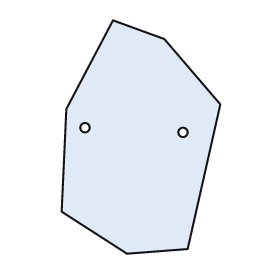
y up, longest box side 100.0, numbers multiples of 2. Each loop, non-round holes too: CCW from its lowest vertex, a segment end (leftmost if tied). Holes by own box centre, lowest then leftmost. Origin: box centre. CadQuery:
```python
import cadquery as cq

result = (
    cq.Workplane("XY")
    .moveTo(-6.0, -50.0)
    .lineTo(20.0, -48.0)
    .lineTo(34.0, 14.0)
    .lineTo(10.0, 42.0)
    .lineTo(-12.0, 50.0)
    .lineTo(-32.0, 12.0)
    .lineTo(-34.0, -32.0)
    .close()
    .moveTo(18.0, 2.0)
    .circle(2.0)
    .moveTo(-24.0, 4.0)
    .circle(2.0)
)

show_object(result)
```